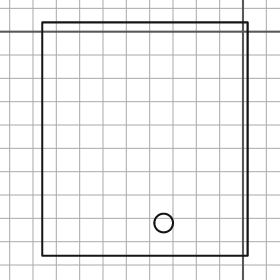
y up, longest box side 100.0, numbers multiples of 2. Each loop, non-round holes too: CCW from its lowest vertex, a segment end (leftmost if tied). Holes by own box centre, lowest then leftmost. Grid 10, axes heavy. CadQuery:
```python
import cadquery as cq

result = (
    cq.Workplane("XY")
    .moveTo(-86.0, -96.0)
    .lineTo(2.0, -96.0)
    .lineTo(2.0, 4.0)
    .lineTo(-86.0, 4.0)
    .close()
    .moveTo(-34.0, -82.0)
    .circle(4.0)
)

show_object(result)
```